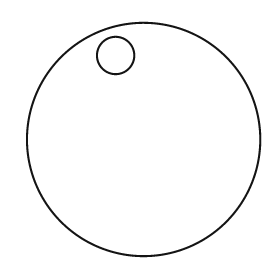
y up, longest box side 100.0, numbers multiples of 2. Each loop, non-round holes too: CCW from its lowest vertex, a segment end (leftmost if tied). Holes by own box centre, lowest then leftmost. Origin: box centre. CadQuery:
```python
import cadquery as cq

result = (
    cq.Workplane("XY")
    .moveTo(0.0, 0.0)
    .circle(50.0)
    .moveTo(-12.0, 36.0)
    .circle(8.0)
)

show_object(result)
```